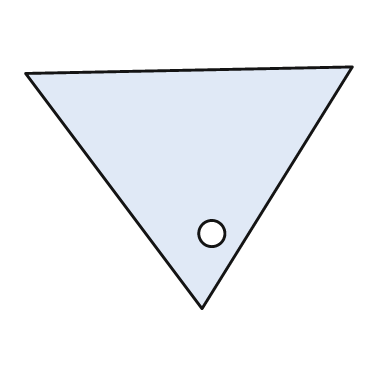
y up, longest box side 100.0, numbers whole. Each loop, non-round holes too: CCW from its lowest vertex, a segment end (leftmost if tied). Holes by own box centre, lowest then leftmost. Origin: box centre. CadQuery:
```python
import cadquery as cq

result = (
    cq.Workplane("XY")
    .moveTo(4.0, -37.0)
    .lineTo(50.0, 37.0)
    .lineTo(-50.0, 35.0)
    .close()
    .moveTo(7.0, -14.0)
    .circle(4.0)
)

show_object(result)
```